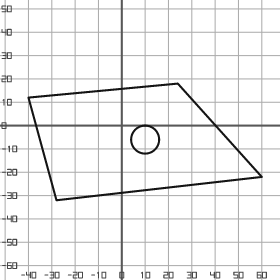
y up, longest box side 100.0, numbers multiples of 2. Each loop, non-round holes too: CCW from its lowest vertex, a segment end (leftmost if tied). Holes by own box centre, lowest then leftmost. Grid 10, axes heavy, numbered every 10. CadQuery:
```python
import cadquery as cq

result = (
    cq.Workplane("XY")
    .moveTo(-28.0, -32.0)
    .lineTo(60.0, -22.0)
    .lineTo(24.0, 18.0)
    .lineTo(-40.0, 12.0)
    .close()
    .moveTo(10.0, -6.0)
    .circle(6.0)
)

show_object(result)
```